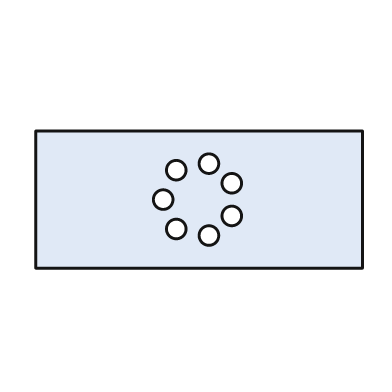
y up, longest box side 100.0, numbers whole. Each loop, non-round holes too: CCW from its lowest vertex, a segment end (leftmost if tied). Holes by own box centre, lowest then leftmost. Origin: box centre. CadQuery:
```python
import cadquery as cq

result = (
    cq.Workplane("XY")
    .moveTo(-50.0, -21.0)
    .lineTo(50.0, -21.0)
    .lineTo(50.0, 21.0)
    .lineTo(-50.0, 21.0)
    .close()
    .moveTo(3.0, -11.0)
    .circle(3.0)
    .moveTo(-7.0, -9.0)
    .circle(3.0)
    .moveTo(10.0, -5.0)
    .circle(3.0)
    .moveTo(-11.0, 0.0)
    .circle(3.0)
    .moveTo(10.0, 5.0)
    .circle(3.0)
    .moveTo(-7.0, 9.0)
    .circle(3.0)
    .moveTo(3.0, 11.0)
    .circle(3.0)
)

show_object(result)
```